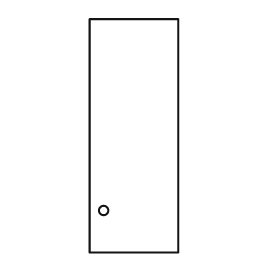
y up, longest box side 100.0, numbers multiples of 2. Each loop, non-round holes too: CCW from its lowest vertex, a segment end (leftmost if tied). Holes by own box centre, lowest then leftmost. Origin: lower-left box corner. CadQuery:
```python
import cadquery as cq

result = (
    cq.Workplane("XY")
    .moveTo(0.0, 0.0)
    .lineTo(38.0, 0.0)
    .lineTo(38.0, 100.0)
    .lineTo(0.0, 100.0)
    .close()
    .moveTo(6.0, 18.0)
    .circle(2.0)
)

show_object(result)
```